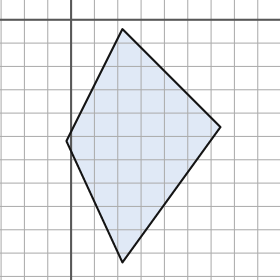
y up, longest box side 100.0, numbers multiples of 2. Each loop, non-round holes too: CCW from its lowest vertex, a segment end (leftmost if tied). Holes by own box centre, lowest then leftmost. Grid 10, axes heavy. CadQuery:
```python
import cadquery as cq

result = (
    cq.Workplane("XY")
    .moveTo(22.0, -104.0)
    .lineTo(64.0, -46.0)
    .lineTo(22.0, -4.0)
    .lineTo(-2.0, -52.0)
    .close()
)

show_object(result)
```